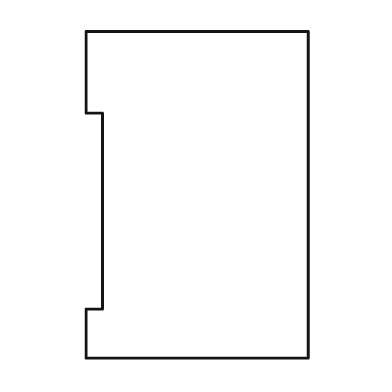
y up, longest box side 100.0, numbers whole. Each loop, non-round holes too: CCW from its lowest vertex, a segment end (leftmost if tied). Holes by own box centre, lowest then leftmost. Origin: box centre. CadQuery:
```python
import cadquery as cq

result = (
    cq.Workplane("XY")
    .moveTo(-34.0, -50.0)
    .lineTo(34.0, -50.0)
    .lineTo(34.0, 50.0)
    .lineTo(-34.0, 50.0)
    .lineTo(-34.0, 25.0)
    .lineTo(-29.0, 25.0)
    .lineTo(-29.0, -35.0)
    .lineTo(-34.0, -35.0)
    .close()
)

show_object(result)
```